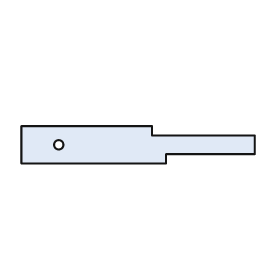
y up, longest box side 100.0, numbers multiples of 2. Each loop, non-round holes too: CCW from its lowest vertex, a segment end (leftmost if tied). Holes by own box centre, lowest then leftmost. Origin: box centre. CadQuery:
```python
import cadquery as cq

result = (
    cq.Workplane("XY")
    .moveTo(-50.0, -8.0)
    .lineTo(12.0, -8.0)
    .lineTo(12.0, -4.0)
    .lineTo(50.0, -4.0)
    .lineTo(50.0, 4.0)
    .lineTo(6.0, 4.0)
    .lineTo(6.0, 8.0)
    .lineTo(-50.0, 8.0)
    .close()
    .moveTo(-34.0, 0.0)
    .circle(2.0)
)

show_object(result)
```